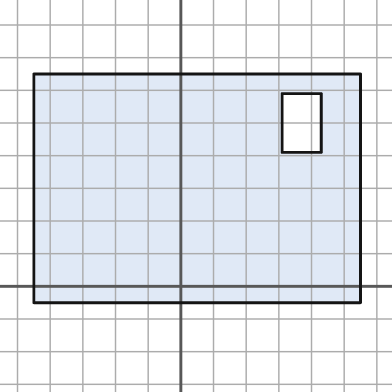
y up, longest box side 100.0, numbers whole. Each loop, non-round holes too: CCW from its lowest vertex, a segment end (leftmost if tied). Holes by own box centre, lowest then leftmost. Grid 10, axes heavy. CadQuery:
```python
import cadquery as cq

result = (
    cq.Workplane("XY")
    .moveTo(-45.0, -5.0)
    .lineTo(55.0, -5.0)
    .lineTo(55.0, 65.0)
    .lineTo(-45.0, 65.0)
    .close()
    .moveTo(31.0, 41.0)
    .lineTo(43.0, 41.0)
    .lineTo(43.0, 59.0)
    .lineTo(31.0, 59.0)
    .close()
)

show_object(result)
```